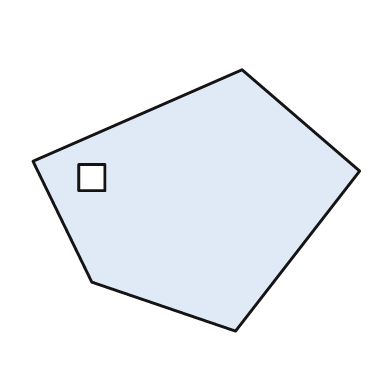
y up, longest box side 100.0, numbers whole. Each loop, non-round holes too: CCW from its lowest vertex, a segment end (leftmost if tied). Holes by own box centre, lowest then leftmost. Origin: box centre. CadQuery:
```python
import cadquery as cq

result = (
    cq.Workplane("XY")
    .moveTo(12.0, -40.0)
    .lineTo(50.0, 9.0)
    .lineTo(14.0, 40.0)
    .lineTo(-50.0, 12.0)
    .lineTo(-32.0, -25.0)
    .close()
    .moveTo(-36.0, 3.0)
    .lineTo(-28.0, 3.0)
    .lineTo(-28.0, 11.0)
    .lineTo(-36.0, 11.0)
    .close()
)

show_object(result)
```